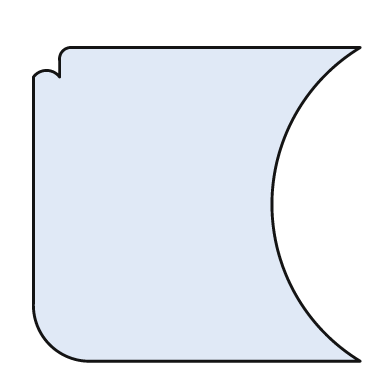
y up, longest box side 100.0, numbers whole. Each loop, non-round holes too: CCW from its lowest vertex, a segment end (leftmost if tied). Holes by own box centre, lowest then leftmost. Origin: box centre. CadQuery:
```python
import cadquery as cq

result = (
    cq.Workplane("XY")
    .moveTo(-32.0, -48.0)
    .lineTo(50.0, -48.0)
    .threePointArc((23.0, 0.0), (50.0, 48.0))
    .lineTo(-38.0, 48.0)
    .threePointArc((-41.0, 47.0), (-42.0, 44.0))
    .lineTo(-42.0, 39.0)
    .threePointArc((-46.0, 41.0), (-50.0, 39.0))
    .lineTo(-50.0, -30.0)
    .threePointArc((-45.0, -43.0), (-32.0, -48.0))
    .close()
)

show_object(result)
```